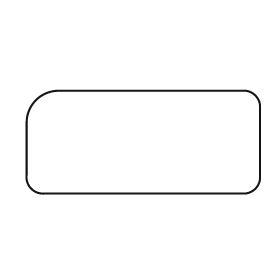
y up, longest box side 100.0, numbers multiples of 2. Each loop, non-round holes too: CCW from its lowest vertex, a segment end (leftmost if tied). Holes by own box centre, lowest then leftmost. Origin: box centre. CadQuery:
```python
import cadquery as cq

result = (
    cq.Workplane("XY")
    .moveTo(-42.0, -22.0)
    .lineTo(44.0, -22.0)
    .threePointArc((48.0, -20.0), (50.0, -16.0))
    .lineTo(50.0, 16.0)
    .threePointArc((48.0, 20.0), (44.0, 22.0))
    .lineTo(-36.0, 22.0)
    .threePointArc((-46.0, 18.0), (-50.0, 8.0))
    .lineTo(-50.0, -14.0)
    .threePointArc((-48.0, -20.0), (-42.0, -22.0))
    .close()
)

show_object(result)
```